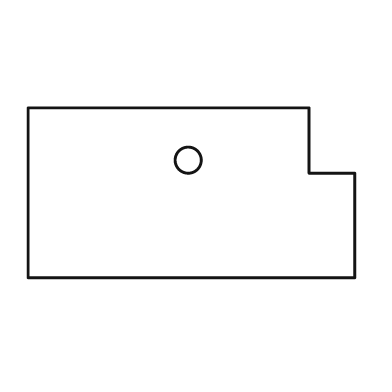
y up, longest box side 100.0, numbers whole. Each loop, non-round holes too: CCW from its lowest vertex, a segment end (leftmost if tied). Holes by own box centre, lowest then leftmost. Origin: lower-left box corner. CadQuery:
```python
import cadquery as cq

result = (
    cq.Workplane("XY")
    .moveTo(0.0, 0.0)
    .lineTo(100.0, 0.0)
    .lineTo(100.0, 32.0)
    .lineTo(86.0, 32.0)
    .lineTo(86.0, 52.0)
    .lineTo(0.0, 52.0)
    .close()
    .moveTo(49.0, 36.0)
    .circle(4.0)
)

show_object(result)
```